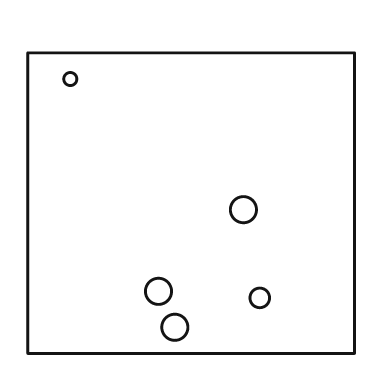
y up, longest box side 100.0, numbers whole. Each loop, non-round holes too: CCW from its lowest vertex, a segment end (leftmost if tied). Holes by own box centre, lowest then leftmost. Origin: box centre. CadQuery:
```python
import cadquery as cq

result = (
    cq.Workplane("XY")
    .moveTo(-50.0, -46.0)
    .lineTo(50.0, -46.0)
    .lineTo(50.0, 46.0)
    .lineTo(-50.0, 46.0)
    .close()
    .moveTo(-5.0, -38.0)
    .circle(4.0)
    .moveTo(21.0, -29.0)
    .circle(3.0)
    .moveTo(-10.0, -27.0)
    .circle(4.0)
    .moveTo(16.0, -2.0)
    .circle(4.0)
    .moveTo(-37.0, 38.0)
    .circle(2.0)
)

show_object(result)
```